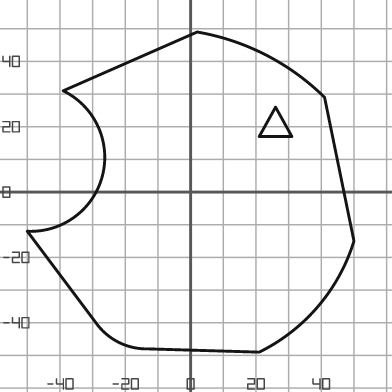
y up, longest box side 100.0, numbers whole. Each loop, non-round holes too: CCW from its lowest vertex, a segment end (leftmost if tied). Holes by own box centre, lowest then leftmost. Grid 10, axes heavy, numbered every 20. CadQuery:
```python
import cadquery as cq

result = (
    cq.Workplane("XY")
    .moveTo(21.0, -49.0)
    .threePointArc((39.0, -35.0), (50.0, -15.0))
    .lineTo(41.0, 29.0)
    .threePointArc((23.0, 42.0), (2.0, 49.0))
    .lineTo(-39.0, 31.0)
    .threePointArc((-27.0, 5.0), (-50.0, -12.0))
    .lineTo(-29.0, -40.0)
    .threePointArc((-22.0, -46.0), (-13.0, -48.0))
    .close()
    .moveTo(21.0, 17.0)
    .lineTo(31.0, 17.0)
    .lineTo(26.0, 26.0)
    .close()
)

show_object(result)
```